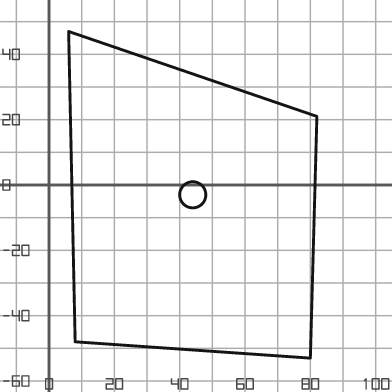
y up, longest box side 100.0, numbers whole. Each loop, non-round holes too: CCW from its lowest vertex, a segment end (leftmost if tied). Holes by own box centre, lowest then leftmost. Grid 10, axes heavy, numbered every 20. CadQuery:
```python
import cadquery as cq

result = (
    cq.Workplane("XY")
    .moveTo(80.0, -53.0)
    .lineTo(82.0, 21.0)
    .lineTo(6.0, 47.0)
    .lineTo(8.0, -48.0)
    .close()
    .moveTo(44.0, -3.0)
    .circle(4.0)
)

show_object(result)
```